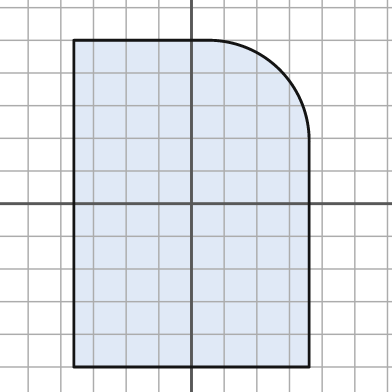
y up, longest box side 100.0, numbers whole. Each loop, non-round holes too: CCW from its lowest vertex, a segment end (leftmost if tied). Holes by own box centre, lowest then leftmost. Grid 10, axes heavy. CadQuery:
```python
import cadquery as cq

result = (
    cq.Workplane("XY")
    .moveTo(-36.0, -50.0)
    .lineTo(36.0, -50.0)
    .lineTo(36.0, 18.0)
    .threePointArc((27.0, 41.0), (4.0, 50.0))
    .lineTo(-36.0, 50.0)
    .close()
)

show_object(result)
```